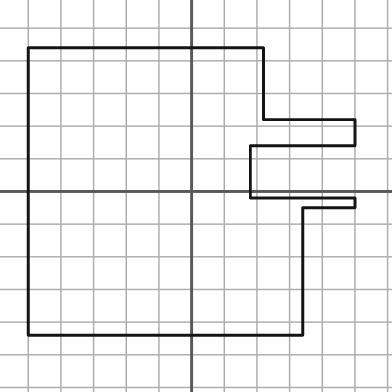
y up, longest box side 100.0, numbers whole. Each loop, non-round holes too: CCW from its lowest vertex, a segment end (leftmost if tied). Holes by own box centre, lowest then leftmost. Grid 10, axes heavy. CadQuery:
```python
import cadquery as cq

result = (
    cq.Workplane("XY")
    .moveTo(-50.0, -44.0)
    .lineTo(34.0, -44.0)
    .lineTo(34.0, -5.0)
    .lineTo(50.0, -5.0)
    .lineTo(50.0, -2.0)
    .lineTo(18.0, -2.0)
    .lineTo(18.0, 14.0)
    .lineTo(50.0, 14.0)
    .lineTo(50.0, 22.0)
    .lineTo(22.0, 22.0)
    .lineTo(22.0, 44.0)
    .lineTo(-50.0, 44.0)
    .close()
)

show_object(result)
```